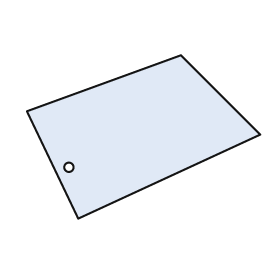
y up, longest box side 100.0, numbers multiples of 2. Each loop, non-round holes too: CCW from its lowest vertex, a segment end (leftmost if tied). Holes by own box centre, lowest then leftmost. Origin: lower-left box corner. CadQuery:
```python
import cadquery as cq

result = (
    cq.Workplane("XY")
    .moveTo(22.0, 0.0)
    .lineTo(100.0, 36.0)
    .lineTo(66.0, 70.0)
    .lineTo(0.0, 46.0)
    .close()
    .moveTo(18.0, 22.0)
    .circle(2.0)
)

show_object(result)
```